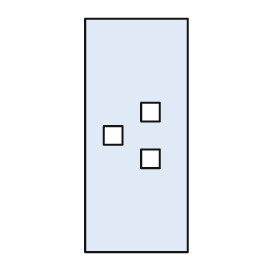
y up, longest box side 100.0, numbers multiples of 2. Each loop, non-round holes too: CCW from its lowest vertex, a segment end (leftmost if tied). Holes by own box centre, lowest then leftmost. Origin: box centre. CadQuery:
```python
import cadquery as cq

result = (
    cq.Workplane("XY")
    .moveTo(-22.0, -50.0)
    .lineTo(22.0, -50.0)
    .lineTo(22.0, 50.0)
    .lineTo(-22.0, 50.0)
    .close()
    .moveTo(2.0, -14.0)
    .lineTo(10.0, -14.0)
    .lineTo(10.0, -6.0)
    .lineTo(2.0, -6.0)
    .close()
    .moveTo(-14.0, -4.0)
    .lineTo(-6.0, -4.0)
    .lineTo(-6.0, 4.0)
    .lineTo(-14.0, 4.0)
    .close()
    .moveTo(2.0, 6.0)
    .lineTo(10.0, 6.0)
    .lineTo(10.0, 14.0)
    .lineTo(2.0, 14.0)
    .close()
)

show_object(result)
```